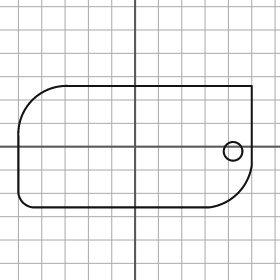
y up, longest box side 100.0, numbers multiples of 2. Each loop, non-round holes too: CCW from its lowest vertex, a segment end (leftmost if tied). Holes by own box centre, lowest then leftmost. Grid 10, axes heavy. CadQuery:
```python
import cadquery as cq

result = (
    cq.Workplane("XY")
    .moveTo(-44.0, -26.0)
    .lineTo(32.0, -26.0)
    .threePointArc((44.0, -20.0), (50.0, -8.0))
    .lineTo(50.0, 26.0)
    .lineTo(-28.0, 26.0)
    .threePointArc((-44.0, 20.0), (-50.0, 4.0))
    .lineTo(-50.0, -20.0)
    .threePointArc((-48.0, -24.0), (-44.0, -26.0))
    .close()
    .moveTo(42.0, -2.0)
    .circle(4.0)
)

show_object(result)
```